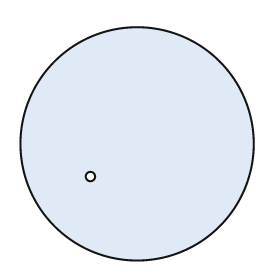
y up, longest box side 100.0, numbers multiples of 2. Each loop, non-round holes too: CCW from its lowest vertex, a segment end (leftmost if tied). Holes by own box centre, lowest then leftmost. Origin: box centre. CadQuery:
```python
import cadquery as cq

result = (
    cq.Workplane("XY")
    .moveTo(0.0, 0.0)
    .circle(50.0)
    .moveTo(-20.0, -14.0)
    .circle(2.0)
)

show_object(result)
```